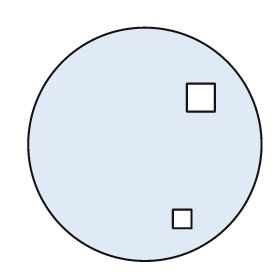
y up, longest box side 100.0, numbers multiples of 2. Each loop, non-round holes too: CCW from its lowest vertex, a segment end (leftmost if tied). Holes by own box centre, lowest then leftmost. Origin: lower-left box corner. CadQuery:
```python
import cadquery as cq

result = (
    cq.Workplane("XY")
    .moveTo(50.0, 50.0)
    .circle(50.0)
    .moveTo(62.0, 14.0)
    .lineTo(70.0, 14.0)
    .lineTo(70.0, 22.0)
    .lineTo(62.0, 22.0)
    .close()
    .moveTo(68.0, 64.0)
    .lineTo(80.0, 64.0)
    .lineTo(80.0, 76.0)
    .lineTo(68.0, 76.0)
    .close()
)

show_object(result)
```